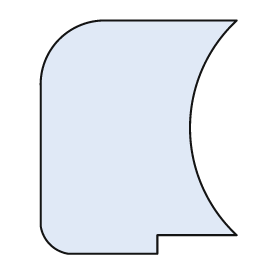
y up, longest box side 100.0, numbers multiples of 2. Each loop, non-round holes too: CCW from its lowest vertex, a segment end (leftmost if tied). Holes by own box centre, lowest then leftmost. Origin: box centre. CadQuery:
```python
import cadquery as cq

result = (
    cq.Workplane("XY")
    .moveTo(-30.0, -50.0)
    .lineTo(8.0, -50.0)
    .lineTo(8.0, -42.0)
    .lineTo(42.0, -42.0)
    .threePointArc((22.0, 4.0), (42.0, 50.0))
    .lineTo(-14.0, 50.0)
    .threePointArc((-34.0, 42.0), (-42.0, 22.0))
    .lineTo(-42.0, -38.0)
    .threePointArc((-38.0, -46.0), (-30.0, -50.0))
    .close()
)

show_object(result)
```